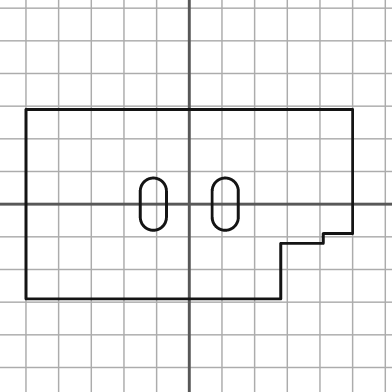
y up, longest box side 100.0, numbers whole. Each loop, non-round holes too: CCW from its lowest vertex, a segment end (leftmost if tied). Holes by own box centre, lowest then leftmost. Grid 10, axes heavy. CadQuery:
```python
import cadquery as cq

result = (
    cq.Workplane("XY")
    .moveTo(-50.0, -29.0)
    .lineTo(28.0, -29.0)
    .lineTo(28.0, -12.0)
    .lineTo(41.0, -12.0)
    .lineTo(41.0, -9.0)
    .lineTo(50.0, -9.0)
    .lineTo(50.0, 29.0)
    .lineTo(-50.0, 29.0)
    .close()
    .moveTo(-15.0, -4.0)
    .threePointArc((-11.0, -8.0), (-7.0, -4.0))
    .lineTo(-7.0, 4.0)
    .threePointArc((-11.0, 8.0), (-15.0, 4.0))
    .close()
    .moveTo(7.0, -4.0)
    .threePointArc((11.0, -8.0), (15.0, -4.0))
    .lineTo(15.0, 4.0)
    .threePointArc((11.0, 8.0), (7.0, 4.0))
    .close()
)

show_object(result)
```